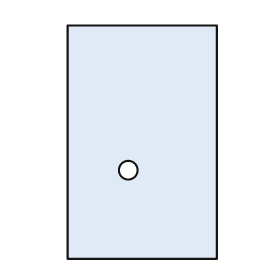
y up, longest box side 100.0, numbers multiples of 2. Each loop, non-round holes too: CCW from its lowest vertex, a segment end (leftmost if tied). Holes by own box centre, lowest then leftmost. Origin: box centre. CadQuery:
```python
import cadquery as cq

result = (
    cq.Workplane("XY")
    .moveTo(-32.0, -50.0)
    .lineTo(32.0, -50.0)
    .lineTo(32.0, 50.0)
    .lineTo(-32.0, 50.0)
    .close()
    .moveTo(-6.0, -12.0)
    .circle(4.0)
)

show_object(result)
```